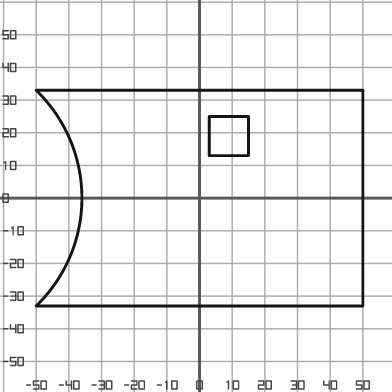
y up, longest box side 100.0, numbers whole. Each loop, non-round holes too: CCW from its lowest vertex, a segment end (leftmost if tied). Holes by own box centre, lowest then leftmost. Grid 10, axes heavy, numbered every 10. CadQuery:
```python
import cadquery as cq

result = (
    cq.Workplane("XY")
    .moveTo(-50.0, -33.0)
    .lineTo(50.0, -33.0)
    .lineTo(50.0, 33.0)
    .lineTo(-50.0, 33.0)
    .threePointArc((-36.0, 0.0), (-50.0, -33.0))
    .close()
    .moveTo(3.0, 13.0)
    .lineTo(15.0, 13.0)
    .lineTo(15.0, 25.0)
    .lineTo(3.0, 25.0)
    .close()
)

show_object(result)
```